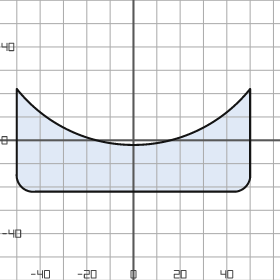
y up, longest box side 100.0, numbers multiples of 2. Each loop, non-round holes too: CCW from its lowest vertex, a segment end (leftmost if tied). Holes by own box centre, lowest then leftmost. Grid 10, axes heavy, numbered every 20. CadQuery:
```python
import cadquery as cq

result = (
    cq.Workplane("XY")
    .moveTo(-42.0, -22.0)
    .lineTo(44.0, -22.0)
    .threePointArc((48.0, -20.0), (50.0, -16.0))
    .lineTo(50.0, 22.0)
    .threePointArc((0.0, -2.0), (-50.0, 22.0))
    .lineTo(-50.0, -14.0)
    .threePointArc((-48.0, -20.0), (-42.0, -22.0))
    .close()
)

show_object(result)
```